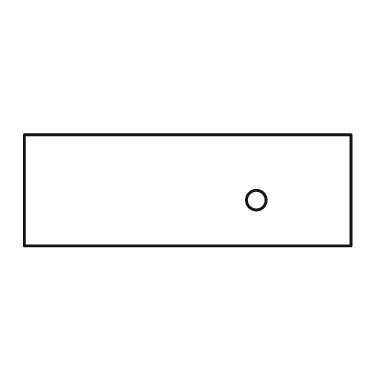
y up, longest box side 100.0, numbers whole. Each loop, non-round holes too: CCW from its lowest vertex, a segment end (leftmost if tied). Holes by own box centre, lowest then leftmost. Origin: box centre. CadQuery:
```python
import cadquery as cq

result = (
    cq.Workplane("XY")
    .moveTo(-50.0, -17.0)
    .lineTo(50.0, -17.0)
    .lineTo(50.0, 17.0)
    .lineTo(-50.0, 17.0)
    .close()
    .moveTo(21.0, -3.0)
    .circle(3.0)
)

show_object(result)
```